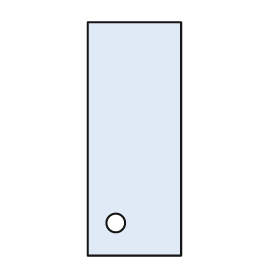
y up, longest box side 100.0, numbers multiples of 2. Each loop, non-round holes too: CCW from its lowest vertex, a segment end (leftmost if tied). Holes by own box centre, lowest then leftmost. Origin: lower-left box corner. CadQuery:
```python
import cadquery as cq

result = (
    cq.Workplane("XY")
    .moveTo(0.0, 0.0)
    .lineTo(40.0, 0.0)
    .lineTo(40.0, 100.0)
    .lineTo(0.0, 100.0)
    .close()
    .moveTo(12.0, 14.0)
    .circle(4.0)
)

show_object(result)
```